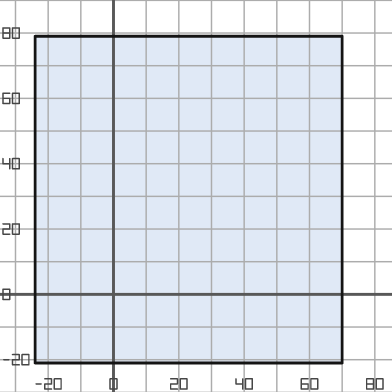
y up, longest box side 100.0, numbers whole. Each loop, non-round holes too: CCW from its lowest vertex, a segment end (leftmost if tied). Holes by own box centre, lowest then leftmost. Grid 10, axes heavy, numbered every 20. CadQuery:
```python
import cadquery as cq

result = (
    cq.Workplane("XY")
    .moveTo(-24.0, -21.0)
    .lineTo(70.0, -21.0)
    .lineTo(70.0, 79.0)
    .lineTo(-24.0, 79.0)
    .close()
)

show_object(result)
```